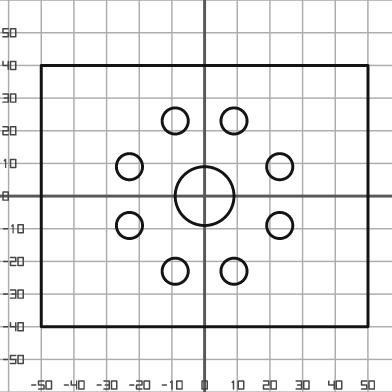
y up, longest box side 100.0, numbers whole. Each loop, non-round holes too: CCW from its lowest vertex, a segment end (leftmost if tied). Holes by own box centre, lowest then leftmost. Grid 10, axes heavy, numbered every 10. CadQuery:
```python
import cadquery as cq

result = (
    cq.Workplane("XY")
    .moveTo(-50.0, -40.0)
    .lineTo(50.0, -40.0)
    .lineTo(50.0, 40.0)
    .lineTo(-50.0, 40.0)
    .close()
    .moveTo(-9.0, -23.0)
    .circle(4.0)
    .moveTo(9.0, -23.0)
    .circle(4.0)
    .moveTo(-23.0, -9.0)
    .circle(4.0)
    .moveTo(23.0, -9.0)
    .circle(4.0)
    .moveTo(0.0, 0.0)
    .circle(9.0)
    .moveTo(-23.0, 9.0)
    .circle(4.0)
    .moveTo(23.0, 9.0)
    .circle(4.0)
    .moveTo(-9.0, 23.0)
    .circle(4.0)
    .moveTo(9.0, 23.0)
    .circle(4.0)
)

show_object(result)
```